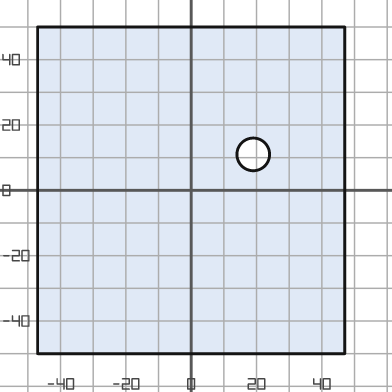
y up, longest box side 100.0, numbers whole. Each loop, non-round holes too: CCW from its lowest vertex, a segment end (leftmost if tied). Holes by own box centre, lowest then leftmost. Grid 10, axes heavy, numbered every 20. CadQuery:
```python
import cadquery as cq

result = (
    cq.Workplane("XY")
    .moveTo(-47.0, -50.0)
    .lineTo(47.0, -50.0)
    .lineTo(47.0, 50.0)
    .lineTo(-47.0, 50.0)
    .close()
    .moveTo(19.0, 11.0)
    .circle(5.0)
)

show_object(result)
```